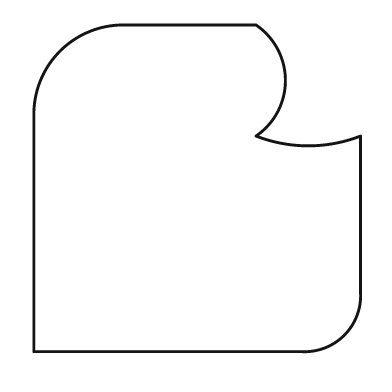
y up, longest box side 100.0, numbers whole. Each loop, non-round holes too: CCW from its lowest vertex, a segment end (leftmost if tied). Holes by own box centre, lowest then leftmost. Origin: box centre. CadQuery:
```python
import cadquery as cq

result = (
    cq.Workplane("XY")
    .moveTo(-50.0, -50.0)
    .lineTo(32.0, -50.0)
    .threePointArc((45.0, -45.0), (50.0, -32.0))
    .lineTo(50.0, 16.0)
    .threePointArc((34.0, 13.0), (18.0, 16.0))
    .threePointArc((27.0, 33.0), (18.0, 50.0))
    .lineTo(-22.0, 50.0)
    .threePointArc((-42.0, 42.0), (-50.0, 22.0))
    .close()
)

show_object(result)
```